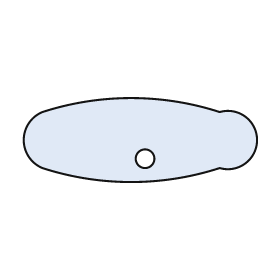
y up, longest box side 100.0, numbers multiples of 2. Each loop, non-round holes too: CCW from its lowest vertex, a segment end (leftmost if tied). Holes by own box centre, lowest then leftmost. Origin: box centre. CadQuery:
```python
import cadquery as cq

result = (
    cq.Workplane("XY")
    .moveTo(-42.0, -12.0)
    .threePointArc((-4.0, -18.0), (34.0, -12.0))
    .threePointArc((50.0, 0.0), (34.0, 12.0))
    .threePointArc((-4.0, 18.0), (-42.0, 12.0))
    .threePointArc((-50.0, 0.0), (-42.0, -12.0))
    .close()
    .moveTo(2.0, -8.0)
    .circle(4.0)
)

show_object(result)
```